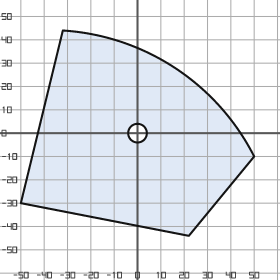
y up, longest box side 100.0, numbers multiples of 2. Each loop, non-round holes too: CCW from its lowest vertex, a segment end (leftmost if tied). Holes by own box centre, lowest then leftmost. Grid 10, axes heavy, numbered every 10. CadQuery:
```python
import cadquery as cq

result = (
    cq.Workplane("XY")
    .moveTo(22.0, -44.0)
    .lineTo(50.0, -10.0)
    .threePointArc((16.0, 28.0), (-32.0, 44.0))
    .lineTo(-50.0, -30.0)
    .close()
    .moveTo(0.0, 0.0)
    .circle(4.0)
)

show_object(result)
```